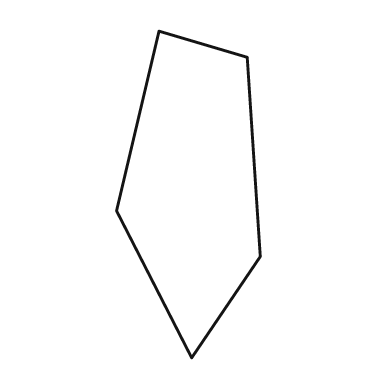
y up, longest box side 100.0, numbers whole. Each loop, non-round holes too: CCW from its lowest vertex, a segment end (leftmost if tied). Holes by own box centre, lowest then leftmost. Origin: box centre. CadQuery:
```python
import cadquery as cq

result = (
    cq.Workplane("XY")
    .moveTo(1.0, -50.0)
    .lineTo(22.0, -19.0)
    .lineTo(18.0, 42.0)
    .lineTo(-9.0, 50.0)
    .lineTo(-22.0, -5.0)
    .close()
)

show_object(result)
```